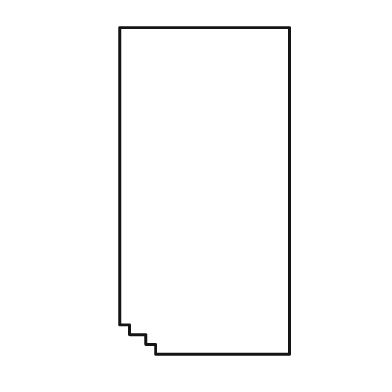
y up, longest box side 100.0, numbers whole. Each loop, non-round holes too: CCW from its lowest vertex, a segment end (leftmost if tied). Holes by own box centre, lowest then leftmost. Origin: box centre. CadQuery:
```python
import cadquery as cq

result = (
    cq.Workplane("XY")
    .moveTo(-15.0, -50.0)
    .lineTo(26.0, -50.0)
    .lineTo(26.0, 50.0)
    .lineTo(-26.0, 50.0)
    .lineTo(-26.0, -41.0)
    .lineTo(-23.0, -41.0)
    .lineTo(-23.0, -44.0)
    .lineTo(-18.0, -44.0)
    .lineTo(-18.0, -47.0)
    .lineTo(-15.0, -47.0)
    .close()
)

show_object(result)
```